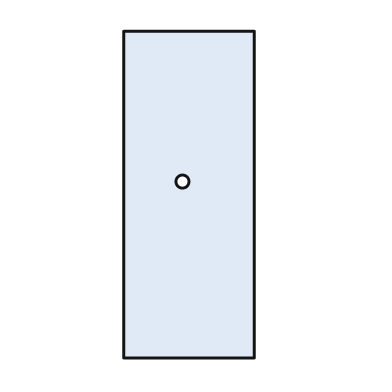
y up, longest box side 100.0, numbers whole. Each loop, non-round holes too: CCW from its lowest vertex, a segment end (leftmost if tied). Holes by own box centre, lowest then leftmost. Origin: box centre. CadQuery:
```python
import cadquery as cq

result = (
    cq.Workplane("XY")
    .moveTo(-20.0, -50.0)
    .lineTo(20.0, -50.0)
    .lineTo(20.0, 50.0)
    .lineTo(-20.0, 50.0)
    .close()
    .moveTo(-2.0, 4.0)
    .circle(2.0)
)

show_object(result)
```